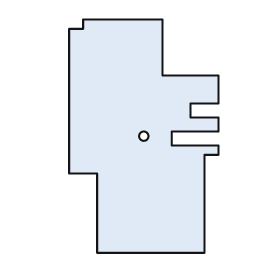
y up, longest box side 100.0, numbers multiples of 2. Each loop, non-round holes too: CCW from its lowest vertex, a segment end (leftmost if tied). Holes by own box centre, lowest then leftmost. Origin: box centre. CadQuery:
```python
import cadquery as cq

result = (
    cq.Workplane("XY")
    .moveTo(-20.0, -50.0)
    .lineTo(26.0, -50.0)
    .lineTo(26.0, -8.0)
    .lineTo(32.0, -8.0)
    .lineTo(32.0, -4.0)
    .lineTo(12.0, -4.0)
    .lineTo(12.0, 2.0)
    .lineTo(32.0, 2.0)
    .lineTo(32.0, 8.0)
    .lineTo(20.0, 8.0)
    .lineTo(20.0, 14.0)
    .lineTo(32.0, 14.0)
    .lineTo(32.0, 26.0)
    .lineTo(8.0, 26.0)
    .lineTo(8.0, 50.0)
    .lineTo(-26.0, 50.0)
    .lineTo(-26.0, 46.0)
    .lineTo(-32.0, 46.0)
    .lineTo(-32.0, -16.0)
    .lineTo(-20.0, -16.0)
    .close()
    .moveTo(0.0, 0.0)
    .circle(2.0)
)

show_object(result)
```